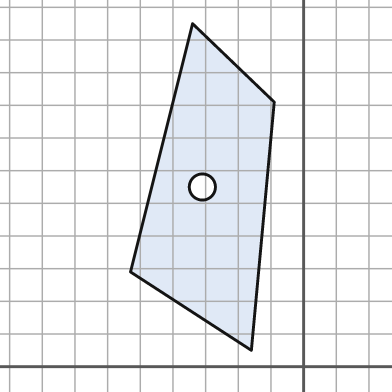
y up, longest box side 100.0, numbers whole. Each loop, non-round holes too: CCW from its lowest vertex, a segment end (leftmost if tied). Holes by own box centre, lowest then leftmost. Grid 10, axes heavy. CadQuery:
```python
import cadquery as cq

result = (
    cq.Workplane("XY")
    .moveTo(-16.0, 5.0)
    .lineTo(-9.0, 81.0)
    .lineTo(-34.0, 105.0)
    .lineTo(-53.0, 29.0)
    .close()
    .moveTo(-31.0, 55.0)
    .circle(4.0)
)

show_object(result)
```